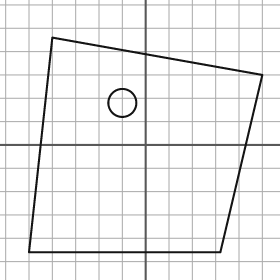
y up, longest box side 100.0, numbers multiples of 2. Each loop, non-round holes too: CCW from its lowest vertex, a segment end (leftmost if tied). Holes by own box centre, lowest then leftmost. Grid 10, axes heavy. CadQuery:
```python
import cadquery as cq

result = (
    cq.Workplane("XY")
    .moveTo(-50.0, -46.0)
    .lineTo(32.0, -46.0)
    .lineTo(50.0, 30.0)
    .lineTo(-40.0, 46.0)
    .close()
    .moveTo(-10.0, 18.0)
    .circle(6.0)
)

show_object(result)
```